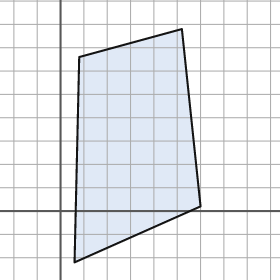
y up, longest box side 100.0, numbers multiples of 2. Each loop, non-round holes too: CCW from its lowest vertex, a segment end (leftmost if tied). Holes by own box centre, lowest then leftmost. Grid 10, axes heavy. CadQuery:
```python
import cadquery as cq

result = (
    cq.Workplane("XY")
    .moveTo(6.0, -22.0)
    .lineTo(60.0, 2.0)
    .lineTo(52.0, 78.0)
    .lineTo(8.0, 66.0)
    .close()
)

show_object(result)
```